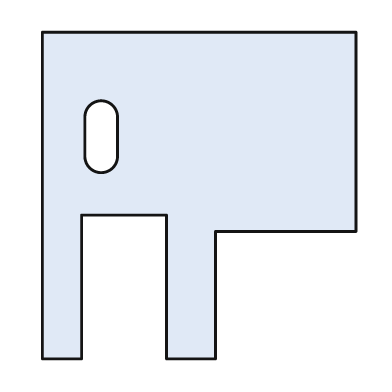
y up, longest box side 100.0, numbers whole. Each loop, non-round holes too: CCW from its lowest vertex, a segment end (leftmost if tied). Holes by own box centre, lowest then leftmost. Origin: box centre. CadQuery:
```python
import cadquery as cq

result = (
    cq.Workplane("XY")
    .moveTo(-48.0, -50.0)
    .lineTo(-36.0, -50.0)
    .lineTo(-36.0, -6.0)
    .lineTo(-10.0, -6.0)
    .lineTo(-10.0, -50.0)
    .lineTo(5.0, -50.0)
    .lineTo(5.0, -11.0)
    .lineTo(48.0, -11.0)
    .lineTo(48.0, 50.0)
    .lineTo(-48.0, 50.0)
    .close()
    .moveTo(-35.0, 12.0)
    .threePointArc((-30.0, 7.0), (-25.0, 12.0))
    .lineTo(-25.0, 24.0)
    .threePointArc((-30.0, 29.0), (-35.0, 24.0))
    .close()
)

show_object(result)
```